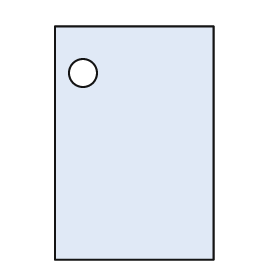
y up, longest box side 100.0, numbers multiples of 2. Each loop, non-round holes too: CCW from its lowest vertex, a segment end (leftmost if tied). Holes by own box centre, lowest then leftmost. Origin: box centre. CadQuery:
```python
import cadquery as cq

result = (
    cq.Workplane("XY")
    .moveTo(-34.0, -50.0)
    .lineTo(34.0, -50.0)
    .lineTo(34.0, 50.0)
    .lineTo(-34.0, 50.0)
    .close()
    .moveTo(-22.0, 30.0)
    .circle(6.0)
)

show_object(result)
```